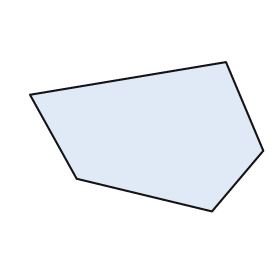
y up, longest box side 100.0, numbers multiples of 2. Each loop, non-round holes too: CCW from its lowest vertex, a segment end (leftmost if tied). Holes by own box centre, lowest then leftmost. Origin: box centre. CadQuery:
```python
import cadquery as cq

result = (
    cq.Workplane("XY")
    .moveTo(28.0, -32.0)
    .lineTo(50.0, -6.0)
    .lineTo(34.0, 32.0)
    .lineTo(-50.0, 18.0)
    .lineTo(-30.0, -18.0)
    .close()
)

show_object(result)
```